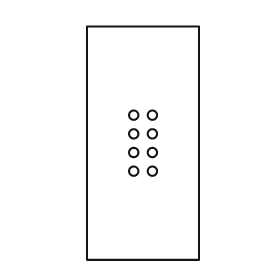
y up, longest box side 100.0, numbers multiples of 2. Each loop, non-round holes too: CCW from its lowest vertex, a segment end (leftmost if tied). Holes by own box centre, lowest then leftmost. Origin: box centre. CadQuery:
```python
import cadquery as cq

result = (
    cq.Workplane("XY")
    .moveTo(-24.0, -50.0)
    .lineTo(24.0, -50.0)
    .lineTo(24.0, 50.0)
    .lineTo(-24.0, 50.0)
    .close()
    .moveTo(-4.0, -12.0)
    .circle(2.0)
    .moveTo(4.0, -12.0)
    .circle(2.0)
    .moveTo(-4.0, -4.0)
    .circle(2.0)
    .moveTo(4.0, -4.0)
    .circle(2.0)
    .moveTo(-4.0, 4.0)
    .circle(2.0)
    .moveTo(4.0, 4.0)
    .circle(2.0)
    .moveTo(-4.0, 12.0)
    .circle(2.0)
    .moveTo(4.0, 12.0)
    .circle(2.0)
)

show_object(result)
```